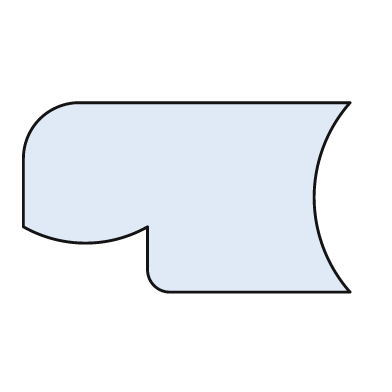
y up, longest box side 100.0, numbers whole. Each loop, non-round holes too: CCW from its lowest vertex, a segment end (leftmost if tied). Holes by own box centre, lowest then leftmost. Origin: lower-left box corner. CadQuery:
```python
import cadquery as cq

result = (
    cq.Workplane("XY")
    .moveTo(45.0, 0.0)
    .lineTo(100.0, 0.0)
    .threePointArc((89.0, 29.0), (100.0, 58.0))
    .lineTo(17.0, 58.0)
    .threePointArc((5.0, 53.0), (0.0, 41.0))
    .lineTo(0.0, 20.0)
    .threePointArc((19.0, 15.0), (38.0, 20.0))
    .lineTo(38.0, 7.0)
    .threePointArc((40.0, 2.0), (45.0, 0.0))
    .close()
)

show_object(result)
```